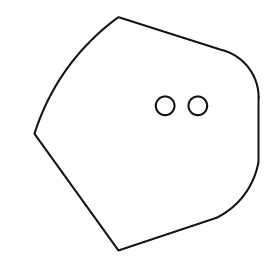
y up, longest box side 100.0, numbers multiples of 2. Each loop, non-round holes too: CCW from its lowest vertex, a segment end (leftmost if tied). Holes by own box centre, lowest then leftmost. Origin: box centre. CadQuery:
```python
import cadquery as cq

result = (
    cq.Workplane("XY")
    .moveTo(-12.0, -50.0)
    .lineTo(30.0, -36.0)
    .threePointArc((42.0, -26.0), (48.0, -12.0))
    .lineTo(48.0, 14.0)
    .threePointArc((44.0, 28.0), (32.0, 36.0))
    .lineTo(-12.0, 50.0)
    .threePointArc((-34.0, 28.0), (-48.0, 0.0))
    .close()
    .moveTo(8.0, 12.0)
    .circle(4.0)
    .moveTo(22.0, 12.0)
    .circle(4.0)
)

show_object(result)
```